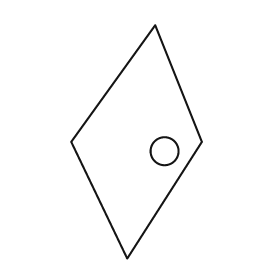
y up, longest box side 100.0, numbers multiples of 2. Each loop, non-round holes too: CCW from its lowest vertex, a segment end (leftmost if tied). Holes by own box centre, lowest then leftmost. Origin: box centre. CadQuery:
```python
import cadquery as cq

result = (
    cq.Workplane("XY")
    .moveTo(-4.0, -50.0)
    .lineTo(28.0, 0.0)
    .lineTo(8.0, 50.0)
    .lineTo(-28.0, 0.0)
    .close()
    .moveTo(12.0, -4.0)
    .circle(6.0)
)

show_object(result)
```